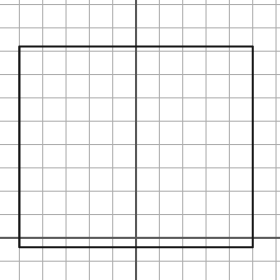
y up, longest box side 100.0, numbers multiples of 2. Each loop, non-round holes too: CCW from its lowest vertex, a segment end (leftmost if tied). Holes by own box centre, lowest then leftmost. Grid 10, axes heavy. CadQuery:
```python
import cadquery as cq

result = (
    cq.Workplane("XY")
    .moveTo(-50.0, -4.0)
    .lineTo(50.0, -4.0)
    .lineTo(50.0, 82.0)
    .lineTo(-50.0, 82.0)
    .close()
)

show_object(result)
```